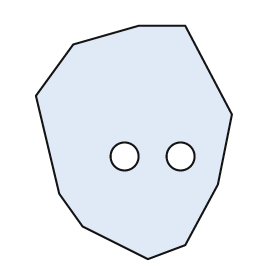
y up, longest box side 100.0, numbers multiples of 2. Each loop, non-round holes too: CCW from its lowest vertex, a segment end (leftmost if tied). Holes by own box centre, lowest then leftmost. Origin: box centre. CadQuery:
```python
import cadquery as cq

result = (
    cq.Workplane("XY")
    .moveTo(6.0, -50.0)
    .lineTo(22.0, -44.0)
    .lineTo(36.0, -18.0)
    .lineTo(42.0, 12.0)
    .lineTo(22.0, 50.0)
    .lineTo(2.0, 50.0)
    .lineTo(-26.0, 42.0)
    .lineTo(-42.0, 20.0)
    .lineTo(-32.0, -22.0)
    .lineTo(-22.0, -36.0)
    .close()
    .moveTo(-4.0, -6.0)
    .circle(6.0)
    .moveTo(20.0, -6.0)
    .circle(6.0)
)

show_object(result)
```